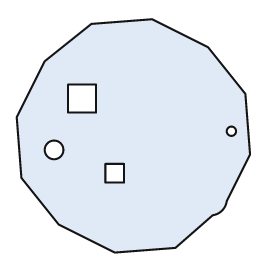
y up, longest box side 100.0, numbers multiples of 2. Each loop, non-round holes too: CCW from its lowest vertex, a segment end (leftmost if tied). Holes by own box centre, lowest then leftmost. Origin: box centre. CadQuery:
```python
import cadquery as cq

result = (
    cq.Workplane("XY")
    .moveTo(-8.0, -50.0)
    .lineTo(18.0, -48.0)
    .lineTo(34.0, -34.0)
    .threePointArc((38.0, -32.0), (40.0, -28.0))
    .lineTo(50.0, -8.0)
    .lineTo(48.0, 18.0)
    .lineTo(32.0, 38.0)
    .lineTo(8.0, 50.0)
    .lineTo(-18.0, 48.0)
    .lineTo(-38.0, 32.0)
    .lineTo(-50.0, 8.0)
    .lineTo(-48.0, -18.0)
    .lineTo(-32.0, -38.0)
    .close()
    .moveTo(-12.0, -20.0)
    .lineTo(-4.0, -20.0)
    .lineTo(-4.0, -12.0)
    .lineTo(-12.0, -12.0)
    .close()
    .moveTo(-34.0, -6.0)
    .circle(4.0)
    .moveTo(42.0, 2.0)
    .circle(2.0)
    .moveTo(-28.0, 10.0)
    .lineTo(-16.0, 10.0)
    .lineTo(-16.0, 22.0)
    .lineTo(-28.0, 22.0)
    .close()
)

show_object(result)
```